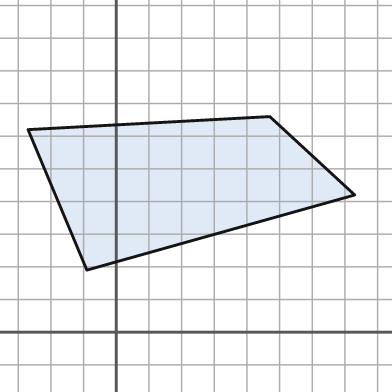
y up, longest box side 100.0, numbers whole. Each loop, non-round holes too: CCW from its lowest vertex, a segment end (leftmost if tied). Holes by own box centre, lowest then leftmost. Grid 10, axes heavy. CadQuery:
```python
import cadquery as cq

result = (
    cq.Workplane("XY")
    .moveTo(-9.0, 19.0)
    .lineTo(73.0, 42.0)
    .lineTo(47.0, 66.0)
    .lineTo(-27.0, 62.0)
    .close()
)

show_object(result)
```